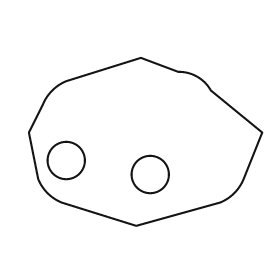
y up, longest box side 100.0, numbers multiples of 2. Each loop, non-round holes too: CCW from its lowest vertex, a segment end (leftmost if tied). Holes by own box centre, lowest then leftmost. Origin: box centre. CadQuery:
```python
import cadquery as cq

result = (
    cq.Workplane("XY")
    .moveTo(-4.0, -36.0)
    .lineTo(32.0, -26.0)
    .threePointArc((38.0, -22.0), (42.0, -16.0))
    .lineTo(50.0, 4.0)
    .lineTo(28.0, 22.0)
    .threePointArc((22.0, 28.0), (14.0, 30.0))
    .lineTo(-2.0, 36.0)
    .lineTo(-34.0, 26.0)
    .threePointArc((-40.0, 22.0), (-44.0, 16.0))
    .lineTo(-50.0, 4.0)
    .lineTo(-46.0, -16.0)
    .threePointArc((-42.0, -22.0), (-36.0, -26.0))
    .close()
    .moveTo(2.0, -14.0)
    .circle(8.0)
    .moveTo(-34.0, -8.0)
    .circle(8.0)
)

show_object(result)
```